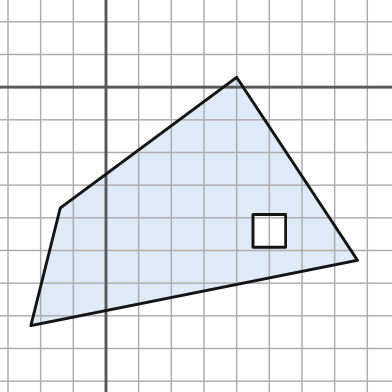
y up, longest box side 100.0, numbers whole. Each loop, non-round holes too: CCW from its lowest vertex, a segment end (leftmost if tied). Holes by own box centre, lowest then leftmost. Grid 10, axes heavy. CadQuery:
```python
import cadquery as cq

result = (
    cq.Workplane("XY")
    .moveTo(-23.0, -73.0)
    .lineTo(77.0, -53.0)
    .lineTo(40.0, 3.0)
    .lineTo(-14.0, -37.0)
    .close()
    .moveTo(45.0, -49.0)
    .lineTo(55.0, -49.0)
    .lineTo(55.0, -39.0)
    .lineTo(45.0, -39.0)
    .close()
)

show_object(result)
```